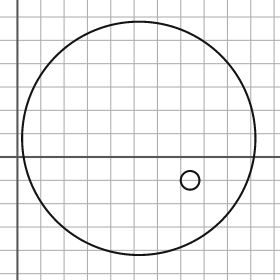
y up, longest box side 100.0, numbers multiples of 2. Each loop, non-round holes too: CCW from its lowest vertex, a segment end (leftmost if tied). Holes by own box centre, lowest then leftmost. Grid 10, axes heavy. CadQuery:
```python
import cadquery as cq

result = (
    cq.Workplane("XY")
    .moveTo(52.0, 8.0)
    .circle(50.0)
    .moveTo(74.0, -10.0)
    .circle(4.0)
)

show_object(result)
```